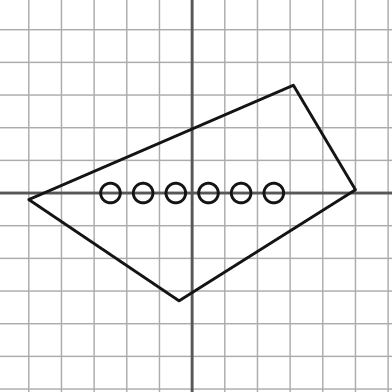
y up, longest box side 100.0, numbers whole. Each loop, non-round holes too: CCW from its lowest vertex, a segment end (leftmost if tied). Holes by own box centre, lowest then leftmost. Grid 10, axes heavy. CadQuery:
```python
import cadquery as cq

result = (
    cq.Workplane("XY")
    .moveTo(-4.0, -33.0)
    .lineTo(50.0, 1.0)
    .lineTo(31.0, 33.0)
    .lineTo(-50.0, -2.0)
    .close()
    .moveTo(-25.0, 0.0)
    .circle(3.0)
    .moveTo(-15.0, 0.0)
    .circle(3.0)
    .moveTo(-5.0, 0.0)
    .circle(3.0)
    .moveTo(5.0, 0.0)
    .circle(3.0)
    .moveTo(15.0, 0.0)
    .circle(3.0)
    .moveTo(25.0, 0.0)
    .circle(3.0)
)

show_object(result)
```